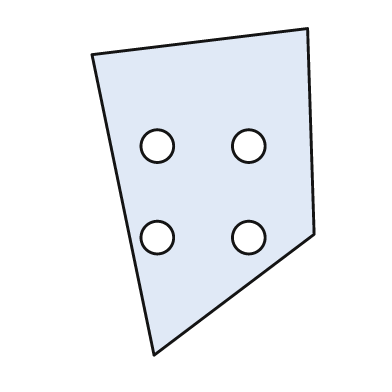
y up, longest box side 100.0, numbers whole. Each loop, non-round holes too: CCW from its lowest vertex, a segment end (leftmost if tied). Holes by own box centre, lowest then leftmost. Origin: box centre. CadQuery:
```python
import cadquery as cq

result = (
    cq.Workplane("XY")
    .moveTo(-15.0, -50.0)
    .lineTo(34.0, -13.0)
    .lineTo(32.0, 50.0)
    .lineTo(-34.0, 42.0)
    .close()
    .moveTo(-14.0, -14.0)
    .circle(5.0)
    .moveTo(14.0, -14.0)
    .circle(5.0)
    .moveTo(-14.0, 14.0)
    .circle(5.0)
    .moveTo(14.0, 14.0)
    .circle(5.0)
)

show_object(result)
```